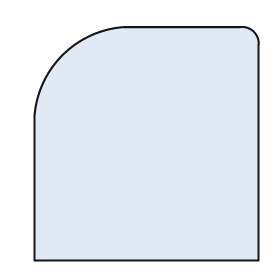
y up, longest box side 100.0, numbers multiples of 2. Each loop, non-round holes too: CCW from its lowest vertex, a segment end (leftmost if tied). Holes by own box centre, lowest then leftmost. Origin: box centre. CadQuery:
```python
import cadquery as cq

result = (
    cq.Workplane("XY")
    .moveTo(-48.0, -50.0)
    .lineTo(48.0, -50.0)
    .lineTo(48.0, 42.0)
    .threePointArc((46.0, 48.0), (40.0, 50.0))
    .lineTo(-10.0, 50.0)
    .threePointArc((-36.0, 38.0), (-48.0, 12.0))
    .close()
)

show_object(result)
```